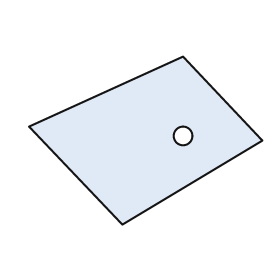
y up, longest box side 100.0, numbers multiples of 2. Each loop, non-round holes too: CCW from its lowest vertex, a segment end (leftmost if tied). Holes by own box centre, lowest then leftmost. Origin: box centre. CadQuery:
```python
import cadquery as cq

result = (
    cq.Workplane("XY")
    .moveTo(-10.0, -36.0)
    .lineTo(50.0, 0.0)
    .lineTo(16.0, 36.0)
    .lineTo(-50.0, 6.0)
    .close()
    .moveTo(16.0, 2.0)
    .circle(4.0)
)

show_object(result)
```